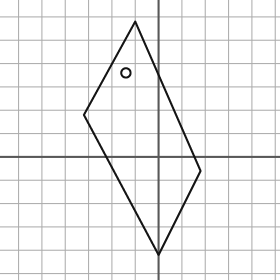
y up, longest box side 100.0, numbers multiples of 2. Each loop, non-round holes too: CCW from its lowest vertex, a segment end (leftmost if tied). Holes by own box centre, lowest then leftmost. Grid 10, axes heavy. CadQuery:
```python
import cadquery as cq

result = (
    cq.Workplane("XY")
    .moveTo(0.0, -42.0)
    .lineTo(18.0, -6.0)
    .lineTo(-10.0, 58.0)
    .lineTo(-32.0, 18.0)
    .close()
    .moveTo(-14.0, 36.0)
    .circle(2.0)
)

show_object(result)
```